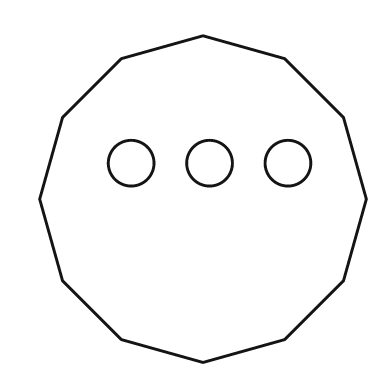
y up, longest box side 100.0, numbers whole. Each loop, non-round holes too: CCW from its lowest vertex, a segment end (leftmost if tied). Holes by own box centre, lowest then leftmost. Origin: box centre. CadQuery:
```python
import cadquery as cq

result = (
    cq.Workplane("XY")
    .moveTo(0.0, -50.0)
    .lineTo(25.0, -43.0)
    .lineTo(43.0, -25.0)
    .lineTo(50.0, 0.0)
    .lineTo(43.0, 25.0)
    .lineTo(25.0, 43.0)
    .lineTo(0.0, 50.0)
    .lineTo(-25.0, 43.0)
    .lineTo(-43.0, 25.0)
    .lineTo(-50.0, 0.0)
    .lineTo(-43.0, -25.0)
    .lineTo(-25.0, -43.0)
    .close()
    .moveTo(-22.0, 11.0)
    .circle(7.0)
    .moveTo(2.0, 11.0)
    .circle(7.0)
    .moveTo(26.0, 11.0)
    .circle(7.0)
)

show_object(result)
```